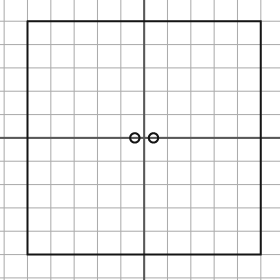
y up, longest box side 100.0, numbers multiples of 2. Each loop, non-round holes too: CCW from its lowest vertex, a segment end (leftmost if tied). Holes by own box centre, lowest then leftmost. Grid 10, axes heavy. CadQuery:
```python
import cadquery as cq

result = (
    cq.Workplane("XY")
    .moveTo(-50.0, -50.0)
    .lineTo(50.0, -50.0)
    .lineTo(50.0, 50.0)
    .lineTo(-50.0, 50.0)
    .close()
    .moveTo(-4.0, 0.0)
    .circle(2.0)
    .moveTo(4.0, 0.0)
    .circle(2.0)
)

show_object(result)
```